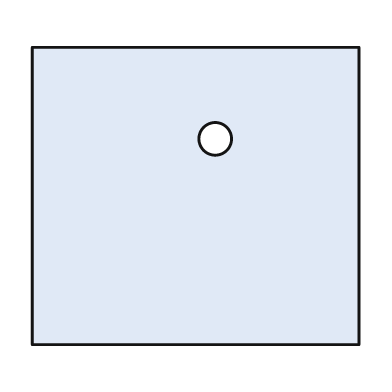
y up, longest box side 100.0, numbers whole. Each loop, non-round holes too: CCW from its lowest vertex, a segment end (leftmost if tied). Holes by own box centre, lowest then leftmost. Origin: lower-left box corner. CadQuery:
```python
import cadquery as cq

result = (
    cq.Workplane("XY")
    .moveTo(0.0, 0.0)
    .lineTo(100.0, 0.0)
    .lineTo(100.0, 91.0)
    .lineTo(0.0, 91.0)
    .close()
    .moveTo(56.0, 63.0)
    .circle(5.0)
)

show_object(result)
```